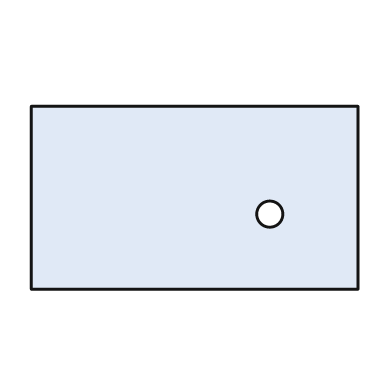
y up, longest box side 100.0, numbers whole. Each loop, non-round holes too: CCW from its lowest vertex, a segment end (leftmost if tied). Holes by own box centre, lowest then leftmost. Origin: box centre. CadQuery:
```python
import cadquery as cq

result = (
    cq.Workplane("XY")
    .moveTo(-50.0, -28.0)
    .lineTo(50.0, -28.0)
    .lineTo(50.0, 28.0)
    .lineTo(-50.0, 28.0)
    .close()
    .moveTo(23.0, -5.0)
    .circle(4.0)
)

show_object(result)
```